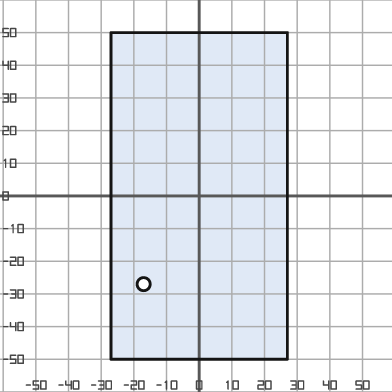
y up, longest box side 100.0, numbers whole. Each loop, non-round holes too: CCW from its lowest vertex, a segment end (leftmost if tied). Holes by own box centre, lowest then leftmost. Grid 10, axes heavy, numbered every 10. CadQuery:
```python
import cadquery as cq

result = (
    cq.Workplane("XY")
    .moveTo(-27.0, -50.0)
    .lineTo(27.0, -50.0)
    .lineTo(27.0, 50.0)
    .lineTo(-27.0, 50.0)
    .close()
    .moveTo(-17.0, -27.0)
    .circle(2.0)
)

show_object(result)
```